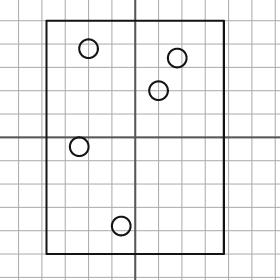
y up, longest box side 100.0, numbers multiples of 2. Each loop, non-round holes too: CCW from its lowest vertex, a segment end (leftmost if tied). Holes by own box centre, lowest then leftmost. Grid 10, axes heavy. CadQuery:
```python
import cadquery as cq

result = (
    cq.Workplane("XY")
    .moveTo(-38.0, -50.0)
    .lineTo(38.0, -50.0)
    .lineTo(38.0, 50.0)
    .lineTo(-38.0, 50.0)
    .close()
    .moveTo(-6.0, -38.0)
    .circle(4.0)
    .moveTo(-24.0, -4.0)
    .circle(4.0)
    .moveTo(10.0, 20.0)
    .circle(4.0)
    .moveTo(18.0, 34.0)
    .circle(4.0)
    .moveTo(-20.0, 38.0)
    .circle(4.0)
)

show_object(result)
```